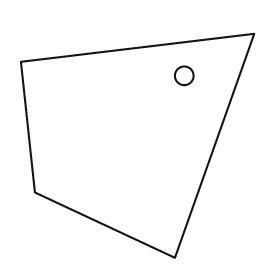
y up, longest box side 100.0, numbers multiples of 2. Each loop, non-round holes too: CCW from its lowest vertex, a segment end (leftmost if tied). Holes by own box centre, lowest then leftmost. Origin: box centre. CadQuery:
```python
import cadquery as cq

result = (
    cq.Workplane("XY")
    .moveTo(16.0, -48.0)
    .lineTo(50.0, 48.0)
    .lineTo(-50.0, 36.0)
    .lineTo(-44.0, -20.0)
    .close()
    .moveTo(20.0, 30.0)
    .circle(4.0)
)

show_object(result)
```